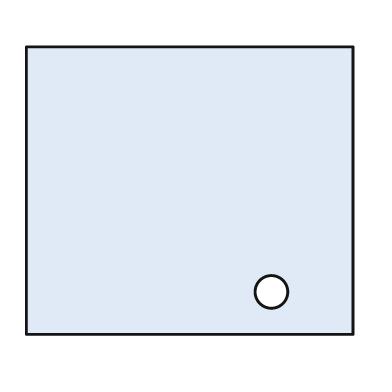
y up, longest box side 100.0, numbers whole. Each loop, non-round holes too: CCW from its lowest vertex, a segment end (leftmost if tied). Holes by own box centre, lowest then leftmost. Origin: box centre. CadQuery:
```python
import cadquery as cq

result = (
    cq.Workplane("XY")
    .moveTo(-50.0, -44.0)
    .lineTo(50.0, -44.0)
    .lineTo(50.0, 44.0)
    .lineTo(-50.0, 44.0)
    .close()
    .moveTo(25.0, -31.0)
    .circle(5.0)
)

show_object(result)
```